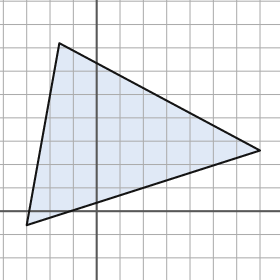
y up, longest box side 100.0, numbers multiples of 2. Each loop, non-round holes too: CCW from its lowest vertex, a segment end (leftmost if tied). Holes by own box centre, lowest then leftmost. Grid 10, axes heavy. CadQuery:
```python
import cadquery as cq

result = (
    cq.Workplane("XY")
    .moveTo(-30.0, -6.0)
    .lineTo(70.0, 26.0)
    .lineTo(-16.0, 72.0)
    .close()
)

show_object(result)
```